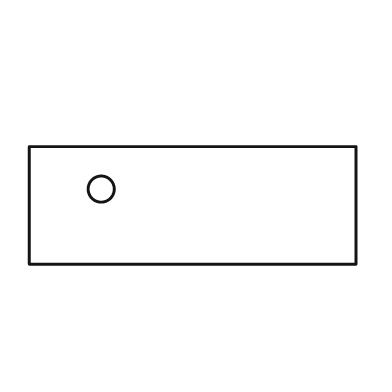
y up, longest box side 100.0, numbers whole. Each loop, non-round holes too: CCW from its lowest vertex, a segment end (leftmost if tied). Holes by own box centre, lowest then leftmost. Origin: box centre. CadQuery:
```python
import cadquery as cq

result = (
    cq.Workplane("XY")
    .moveTo(-50.0, -18.0)
    .lineTo(50.0, -18.0)
    .lineTo(50.0, 18.0)
    .lineTo(-50.0, 18.0)
    .close()
    .moveTo(-28.0, 5.0)
    .circle(4.0)
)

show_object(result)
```